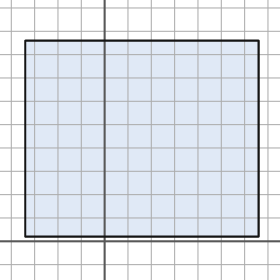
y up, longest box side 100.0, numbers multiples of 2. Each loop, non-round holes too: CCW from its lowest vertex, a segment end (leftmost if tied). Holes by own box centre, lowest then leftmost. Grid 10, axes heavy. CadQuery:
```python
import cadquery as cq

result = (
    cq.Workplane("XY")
    .moveTo(-34.0, 2.0)
    .lineTo(66.0, 2.0)
    .lineTo(66.0, 86.0)
    .lineTo(-34.0, 86.0)
    .close()
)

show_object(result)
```